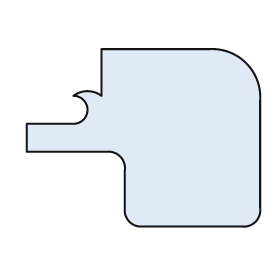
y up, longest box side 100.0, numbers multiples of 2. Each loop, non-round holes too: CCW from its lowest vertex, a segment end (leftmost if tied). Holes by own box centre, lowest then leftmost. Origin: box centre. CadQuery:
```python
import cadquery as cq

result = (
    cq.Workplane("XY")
    .moveTo(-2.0, -38.0)
    .lineTo(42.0, -38.0)
    .threePointArc((48.0, -36.0), (50.0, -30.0))
    .lineTo(50.0, 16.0)
    .threePointArc((44.0, 32.0), (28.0, 38.0))
    .lineTo(-18.0, 38.0)
    .lineTo(-18.0, 18.0)
    .threePointArc((-24.0, 20.0), (-30.0, 18.0))
    .threePointArc((-24.0, 12.0), (-30.0, 6.0))
    .lineTo(-50.0, 6.0)
    .lineTo(-50.0, -6.0)
    .lineTo(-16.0, -6.0)
    .threePointArc((-10.0, -8.0), (-8.0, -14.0))
    .lineTo(-8.0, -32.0)
    .threePointArc((-6.0, -36.0), (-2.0, -38.0))
    .close()
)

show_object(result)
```